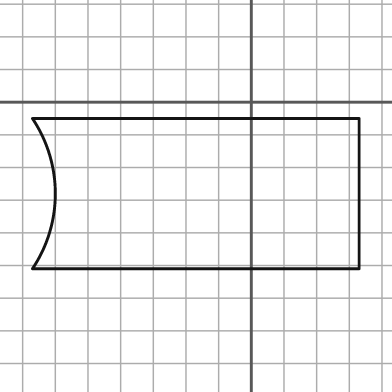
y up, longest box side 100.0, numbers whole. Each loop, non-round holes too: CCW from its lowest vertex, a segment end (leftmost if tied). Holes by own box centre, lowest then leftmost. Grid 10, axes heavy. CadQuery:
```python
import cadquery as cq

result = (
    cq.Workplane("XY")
    .moveTo(-67.0, -51.0)
    .lineTo(33.0, -51.0)
    .lineTo(33.0, -5.0)
    .lineTo(-67.0, -5.0)
    .threePointArc((-60.0, -28.0), (-67.0, -51.0))
    .close()
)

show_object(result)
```